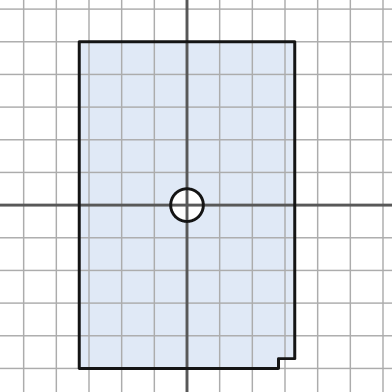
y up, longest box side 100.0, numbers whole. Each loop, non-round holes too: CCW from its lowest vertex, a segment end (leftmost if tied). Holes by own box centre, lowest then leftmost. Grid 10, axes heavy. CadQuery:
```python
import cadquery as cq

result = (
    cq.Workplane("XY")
    .moveTo(-33.0, -50.0)
    .lineTo(28.0, -50.0)
    .lineTo(28.0, -47.0)
    .lineTo(33.0, -47.0)
    .lineTo(33.0, 50.0)
    .lineTo(-33.0, 50.0)
    .close()
    .moveTo(0.0, 0.0)
    .circle(5.0)
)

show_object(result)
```